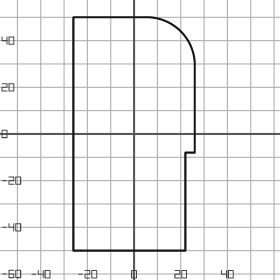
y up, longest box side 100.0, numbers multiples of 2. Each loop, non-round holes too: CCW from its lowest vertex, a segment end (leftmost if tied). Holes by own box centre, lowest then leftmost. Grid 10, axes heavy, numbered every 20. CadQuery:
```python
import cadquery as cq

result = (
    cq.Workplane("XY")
    .moveTo(-26.0, -50.0)
    .lineTo(22.0, -50.0)
    .lineTo(22.0, -8.0)
    .lineTo(26.0, -8.0)
    .lineTo(26.0, 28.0)
    .threePointArc((20.0, 44.0), (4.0, 50.0))
    .lineTo(-26.0, 50.0)
    .close()
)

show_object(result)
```